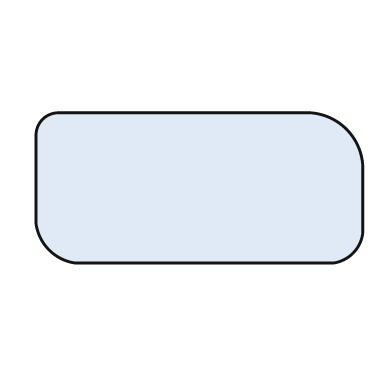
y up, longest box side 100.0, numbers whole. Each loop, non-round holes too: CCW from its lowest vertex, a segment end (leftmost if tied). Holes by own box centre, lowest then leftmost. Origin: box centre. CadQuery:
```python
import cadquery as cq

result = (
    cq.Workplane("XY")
    .moveTo(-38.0, -23.0)
    .lineTo(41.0, -23.0)
    .threePointArc((47.0, -20.0), (50.0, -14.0))
    .lineTo(50.0, 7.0)
    .threePointArc((45.0, 18.0), (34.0, 23.0))
    .lineTo(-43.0, 23.0)
    .threePointArc((-48.0, 21.0), (-50.0, 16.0))
    .lineTo(-50.0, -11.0)
    .threePointArc((-46.0, -19.0), (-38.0, -23.0))
    .close()
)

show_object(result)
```